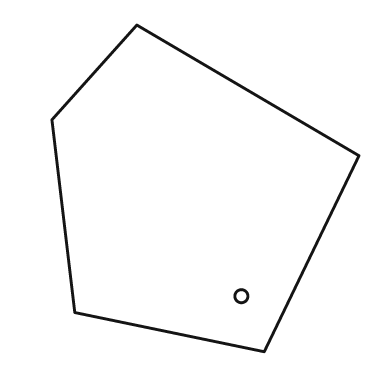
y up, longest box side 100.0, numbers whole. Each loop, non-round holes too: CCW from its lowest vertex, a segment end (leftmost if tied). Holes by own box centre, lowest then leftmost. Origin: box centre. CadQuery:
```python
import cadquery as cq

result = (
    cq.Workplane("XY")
    .moveTo(18.0, -50.0)
    .lineTo(47.0, 10.0)
    .lineTo(-21.0, 50.0)
    .lineTo(-47.0, 21.0)
    .lineTo(-40.0, -38.0)
    .close()
    .moveTo(11.0, -33.0)
    .circle(2.0)
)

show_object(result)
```